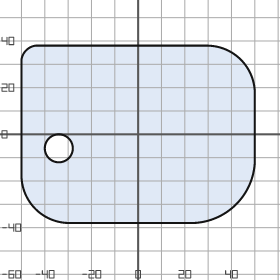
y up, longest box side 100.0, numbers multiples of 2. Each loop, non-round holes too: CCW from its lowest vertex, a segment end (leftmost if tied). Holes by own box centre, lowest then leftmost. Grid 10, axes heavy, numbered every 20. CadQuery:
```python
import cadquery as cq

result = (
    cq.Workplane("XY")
    .moveTo(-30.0, -38.0)
    .lineTo(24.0, -38.0)
    .threePointArc((42.0, -30.0), (50.0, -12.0))
    .lineTo(50.0, 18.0)
    .threePointArc((44.0, 32.0), (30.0, 38.0))
    .lineTo(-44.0, 38.0)
    .threePointArc((-48.0, 36.0), (-50.0, 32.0))
    .lineTo(-50.0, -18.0)
    .threePointArc((-44.0, -32.0), (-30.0, -38.0))
    .close()
    .moveTo(-34.0, -6.0)
    .circle(6.0)
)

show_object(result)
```